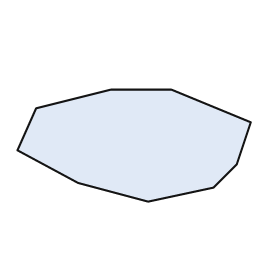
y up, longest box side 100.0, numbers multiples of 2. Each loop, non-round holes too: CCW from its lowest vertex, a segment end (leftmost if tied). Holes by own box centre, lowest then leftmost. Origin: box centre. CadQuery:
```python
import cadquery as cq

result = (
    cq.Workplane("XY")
    .moveTo(6.0, -24.0)
    .lineTo(34.0, -18.0)
    .lineTo(44.0, -8.0)
    .lineTo(50.0, 10.0)
    .lineTo(16.0, 24.0)
    .lineTo(-10.0, 24.0)
    .lineTo(-42.0, 16.0)
    .lineTo(-50.0, -2.0)
    .lineTo(-24.0, -16.0)
    .close()
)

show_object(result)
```